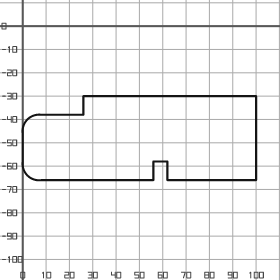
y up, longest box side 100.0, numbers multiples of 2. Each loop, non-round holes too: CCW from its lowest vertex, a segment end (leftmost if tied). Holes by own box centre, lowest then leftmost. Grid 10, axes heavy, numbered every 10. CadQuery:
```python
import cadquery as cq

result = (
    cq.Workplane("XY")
    .moveTo(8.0, -66.0)
    .lineTo(56.0, -66.0)
    .lineTo(56.0, -58.0)
    .lineTo(62.0, -58.0)
    .lineTo(62.0, -66.0)
    .lineTo(100.0, -66.0)
    .lineTo(100.0, -30.0)
    .lineTo(26.0, -30.0)
    .lineTo(26.0, -38.0)
    .lineTo(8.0, -38.0)
    .threePointArc((2.0, -40.0), (0.0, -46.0))
    .lineTo(0.0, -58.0)
    .threePointArc((2.0, -64.0), (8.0, -66.0))
    .close()
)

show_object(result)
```